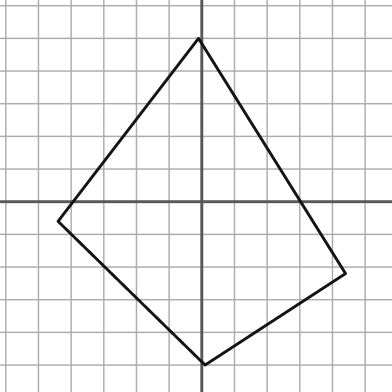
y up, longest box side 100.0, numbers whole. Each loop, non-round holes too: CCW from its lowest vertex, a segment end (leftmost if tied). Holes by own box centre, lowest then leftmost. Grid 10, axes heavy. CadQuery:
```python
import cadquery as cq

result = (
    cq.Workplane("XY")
    .moveTo(1.0, -50.0)
    .lineTo(44.0, -22.0)
    .lineTo(-1.0, 50.0)
    .lineTo(-44.0, -6.0)
    .close()
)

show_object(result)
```